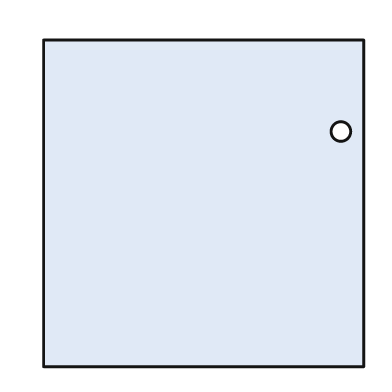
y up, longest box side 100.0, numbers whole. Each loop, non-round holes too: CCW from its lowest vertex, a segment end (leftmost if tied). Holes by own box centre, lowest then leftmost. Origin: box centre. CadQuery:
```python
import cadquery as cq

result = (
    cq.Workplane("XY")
    .moveTo(-49.0, -50.0)
    .lineTo(49.0, -50.0)
    .lineTo(49.0, 50.0)
    .lineTo(-49.0, 50.0)
    .close()
    .moveTo(42.0, 22.0)
    .circle(3.0)
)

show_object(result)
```